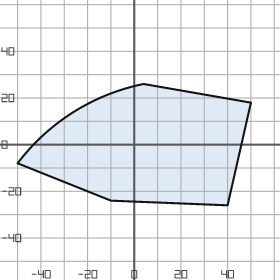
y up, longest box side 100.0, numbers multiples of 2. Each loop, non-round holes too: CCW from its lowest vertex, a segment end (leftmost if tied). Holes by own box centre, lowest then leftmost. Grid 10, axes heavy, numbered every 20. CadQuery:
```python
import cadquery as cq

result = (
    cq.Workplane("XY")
    .moveTo(40.0, -26.0)
    .lineTo(50.0, 18.0)
    .lineTo(4.0, 26.0)
    .threePointArc((-26.0, 14.0), (-50.0, -8.0))
    .lineTo(-10.0, -24.0)
    .close()
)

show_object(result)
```